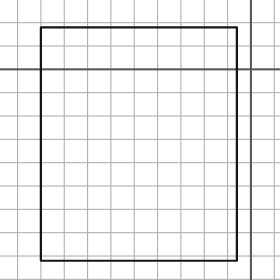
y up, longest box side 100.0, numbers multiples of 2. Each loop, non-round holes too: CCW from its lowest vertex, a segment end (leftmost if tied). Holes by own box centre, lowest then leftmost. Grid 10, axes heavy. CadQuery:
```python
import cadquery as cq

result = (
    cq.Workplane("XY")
    .moveTo(-90.0, -82.0)
    .lineTo(-6.0, -82.0)
    .lineTo(-6.0, 18.0)
    .lineTo(-90.0, 18.0)
    .close()
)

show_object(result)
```